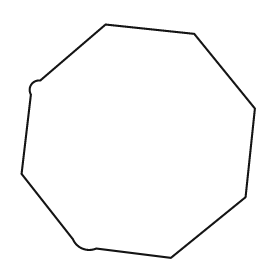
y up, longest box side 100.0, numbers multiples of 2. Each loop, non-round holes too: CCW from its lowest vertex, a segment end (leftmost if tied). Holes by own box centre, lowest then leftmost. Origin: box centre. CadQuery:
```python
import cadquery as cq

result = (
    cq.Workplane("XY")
    .moveTo(14.0, -50.0)
    .lineTo(46.0, -24.0)
    .lineTo(50.0, 14.0)
    .lineTo(24.0, 46.0)
    .lineTo(-14.0, 50.0)
    .lineTo(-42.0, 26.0)
    .threePointArc((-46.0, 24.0), (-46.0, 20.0))
    .lineTo(-50.0, -14.0)
    .lineTo(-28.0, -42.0)
    .threePointArc((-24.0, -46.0), (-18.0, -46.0))
    .close()
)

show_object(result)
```